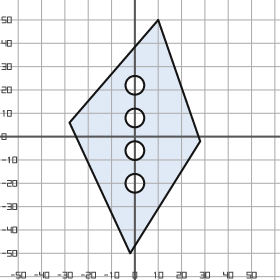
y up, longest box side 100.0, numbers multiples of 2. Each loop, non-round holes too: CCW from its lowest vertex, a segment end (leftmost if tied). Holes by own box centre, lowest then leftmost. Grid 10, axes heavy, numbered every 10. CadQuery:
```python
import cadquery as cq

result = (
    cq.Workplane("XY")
    .moveTo(-2.0, -50.0)
    .lineTo(28.0, -2.0)
    .lineTo(10.0, 50.0)
    .lineTo(-28.0, 6.0)
    .close()
    .moveTo(0.0, -20.0)
    .circle(4.0)
    .moveTo(0.0, -6.0)
    .circle(4.0)
    .moveTo(0.0, 8.0)
    .circle(4.0)
    .moveTo(0.0, 22.0)
    .circle(4.0)
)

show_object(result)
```